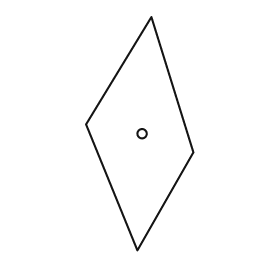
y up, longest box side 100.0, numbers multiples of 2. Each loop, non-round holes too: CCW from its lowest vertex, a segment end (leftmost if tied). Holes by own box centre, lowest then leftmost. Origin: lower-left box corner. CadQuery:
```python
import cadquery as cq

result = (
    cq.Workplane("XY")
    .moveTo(22.0, 0.0)
    .lineTo(46.0, 42.0)
    .lineTo(28.0, 100.0)
    .lineTo(0.0, 54.0)
    .close()
    .moveTo(24.0, 50.0)
    .circle(2.0)
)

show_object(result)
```